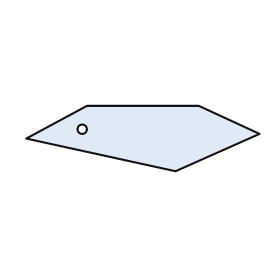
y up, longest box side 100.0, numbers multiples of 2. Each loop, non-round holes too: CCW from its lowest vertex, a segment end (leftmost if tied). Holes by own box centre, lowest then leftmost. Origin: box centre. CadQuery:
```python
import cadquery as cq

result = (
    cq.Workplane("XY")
    .moveTo(14.0, -14.0)
    .lineTo(50.0, 2.0)
    .lineTo(24.0, 14.0)
    .lineTo(-24.0, 14.0)
    .lineTo(-50.0, 0.0)
    .close()
    .moveTo(-26.0, 4.0)
    .circle(2.0)
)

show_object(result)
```